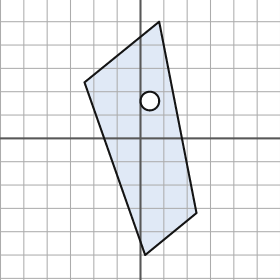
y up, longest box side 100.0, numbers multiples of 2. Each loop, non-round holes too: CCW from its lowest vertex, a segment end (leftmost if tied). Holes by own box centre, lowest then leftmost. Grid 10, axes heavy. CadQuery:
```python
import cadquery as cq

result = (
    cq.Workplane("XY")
    .moveTo(2.0, -50.0)
    .lineTo(24.0, -32.0)
    .lineTo(8.0, 50.0)
    .lineTo(-24.0, 24.0)
    .close()
    .moveTo(4.0, 16.0)
    .circle(4.0)
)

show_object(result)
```